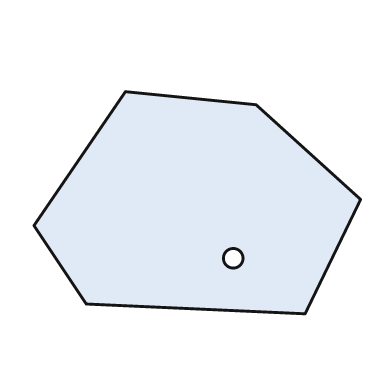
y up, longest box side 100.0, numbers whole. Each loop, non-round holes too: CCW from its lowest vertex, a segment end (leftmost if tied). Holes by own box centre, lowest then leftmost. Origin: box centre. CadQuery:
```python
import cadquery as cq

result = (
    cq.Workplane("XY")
    .moveTo(33.0, -34.0)
    .lineTo(50.0, 1.0)
    .lineTo(18.0, 30.0)
    .lineTo(-22.0, 34.0)
    .lineTo(-50.0, -7.0)
    .lineTo(-34.0, -31.0)
    .close()
    .moveTo(11.0, -17.0)
    .circle(3.0)
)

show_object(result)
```